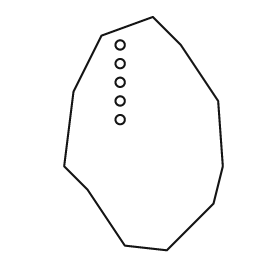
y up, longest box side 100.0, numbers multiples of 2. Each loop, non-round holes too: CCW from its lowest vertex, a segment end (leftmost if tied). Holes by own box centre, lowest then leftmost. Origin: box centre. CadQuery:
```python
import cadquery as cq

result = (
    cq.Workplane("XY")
    .moveTo(10.0, -50.0)
    .lineTo(30.0, -30.0)
    .lineTo(34.0, -14.0)
    .lineTo(32.0, 14.0)
    .lineTo(16.0, 38.0)
    .lineTo(4.0, 50.0)
    .lineTo(-18.0, 42.0)
    .lineTo(-30.0, 18.0)
    .lineTo(-34.0, -14.0)
    .lineTo(-24.0, -24.0)
    .lineTo(-8.0, -48.0)
    .close()
    .moveTo(-10.0, 6.0)
    .circle(2.0)
    .moveTo(-10.0, 14.0)
    .circle(2.0)
    .moveTo(-10.0, 22.0)
    .circle(2.0)
    .moveTo(-10.0, 30.0)
    .circle(2.0)
    .moveTo(-10.0, 38.0)
    .circle(2.0)
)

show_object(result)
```